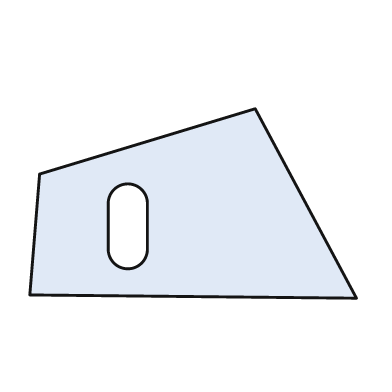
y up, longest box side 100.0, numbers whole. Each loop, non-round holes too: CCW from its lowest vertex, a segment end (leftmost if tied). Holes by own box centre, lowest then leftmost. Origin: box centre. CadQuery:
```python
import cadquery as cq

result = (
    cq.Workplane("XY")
    .moveTo(50.0, -29.0)
    .lineTo(19.0, 29.0)
    .lineTo(-47.0, 9.0)
    .lineTo(-50.0, -28.0)
    .close()
    .moveTo(-26.0, -14.0)
    .threePointArc((-20.0, -20.0), (-14.0, -14.0))
    .lineTo(-14.0, 0.0)
    .threePointArc((-20.0, 6.0), (-26.0, 0.0))
    .close()
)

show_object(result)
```